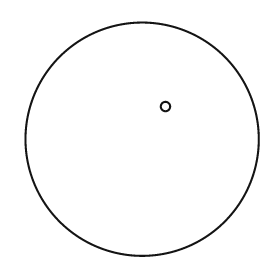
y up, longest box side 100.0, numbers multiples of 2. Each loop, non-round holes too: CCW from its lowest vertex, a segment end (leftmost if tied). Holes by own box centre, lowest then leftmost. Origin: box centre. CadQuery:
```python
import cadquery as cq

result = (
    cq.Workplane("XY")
    .moveTo(0.0, 0.0)
    .circle(50.0)
    .moveTo(10.0, 14.0)
    .circle(2.0)
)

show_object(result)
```